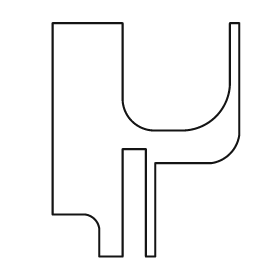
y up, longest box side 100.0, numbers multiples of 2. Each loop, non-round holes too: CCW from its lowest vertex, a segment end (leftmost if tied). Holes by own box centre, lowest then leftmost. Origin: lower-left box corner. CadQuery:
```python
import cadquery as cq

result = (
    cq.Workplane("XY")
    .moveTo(20.0, 0.0)
    .lineTo(30.0, 0.0)
    .lineTo(30.0, 46.0)
    .lineTo(40.0, 46.0)
    .lineTo(40.0, 0.0)
    .lineTo(44.0, 0.0)
    .lineTo(44.0, 40.0)
    .lineTo(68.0, 40.0)
    .threePointArc((76.0, 44.0), (80.0, 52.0))
    .lineTo(80.0, 100.0)
    .lineTo(76.0, 100.0)
    .lineTo(76.0, 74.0)
    .threePointArc((70.0, 60.0), (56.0, 54.0))
    .lineTo(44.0, 54.0)
    .threePointArc((34.0, 58.0), (30.0, 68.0))
    .lineTo(30.0, 100.0)
    .lineTo(0.0, 100.0)
    .lineTo(0.0, 18.0)
    .lineTo(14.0, 18.0)
    .threePointArc((18.0, 16.0), (20.0, 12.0))
    .close()
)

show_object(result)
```